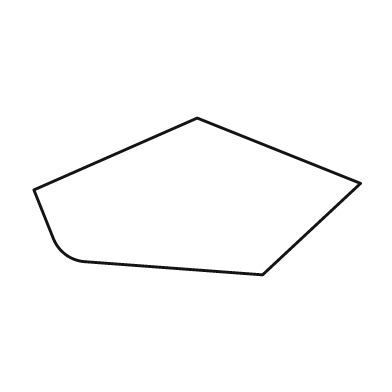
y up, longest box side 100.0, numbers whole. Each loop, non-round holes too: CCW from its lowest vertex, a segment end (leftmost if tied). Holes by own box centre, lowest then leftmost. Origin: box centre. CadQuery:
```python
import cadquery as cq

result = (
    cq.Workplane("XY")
    .moveTo(20.0, -24.0)
    .lineTo(50.0, 4.0)
    .lineTo(0.0, 24.0)
    .lineTo(-50.0, 2.0)
    .lineTo(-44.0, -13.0)
    .threePointArc((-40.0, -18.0), (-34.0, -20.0))
    .close()
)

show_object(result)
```